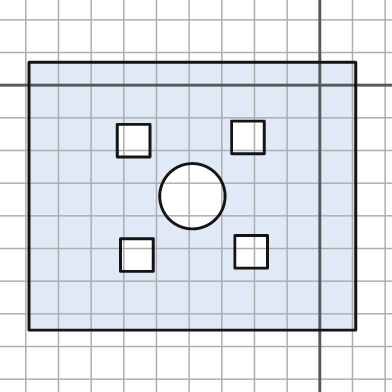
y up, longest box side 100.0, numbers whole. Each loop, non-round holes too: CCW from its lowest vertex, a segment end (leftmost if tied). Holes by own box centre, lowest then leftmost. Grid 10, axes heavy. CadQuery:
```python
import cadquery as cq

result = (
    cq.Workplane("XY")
    .moveTo(-89.0, -75.0)
    .lineTo(11.0, -75.0)
    .lineTo(11.0, 7.0)
    .lineTo(-89.0, 7.0)
    .close()
    .moveTo(-61.0, -57.0)
    .lineTo(-51.0, -57.0)
    .lineTo(-51.0, -47.0)
    .lineTo(-61.0, -47.0)
    .close()
    .moveTo(-26.0, -56.0)
    .lineTo(-16.0, -56.0)
    .lineTo(-16.0, -46.0)
    .lineTo(-26.0, -46.0)
    .close()
    .moveTo(-39.0, -34.0)
    .circle(10.0)
    .moveTo(-62.0, -22.0)
    .lineTo(-52.0, -22.0)
    .lineTo(-52.0, -12.0)
    .lineTo(-62.0, -12.0)
    .close()
    .moveTo(-27.0, -21.0)
    .lineTo(-17.0, -21.0)
    .lineTo(-17.0, -11.0)
    .lineTo(-27.0, -11.0)
    .close()
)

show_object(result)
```